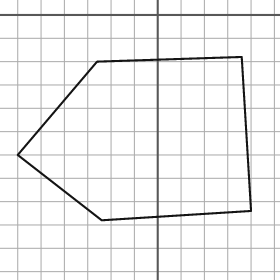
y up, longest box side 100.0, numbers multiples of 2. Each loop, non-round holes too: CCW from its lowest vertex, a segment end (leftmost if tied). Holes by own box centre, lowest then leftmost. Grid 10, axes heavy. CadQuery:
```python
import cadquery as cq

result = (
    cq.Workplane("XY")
    .moveTo(-24.0, -88.0)
    .lineTo(40.0, -84.0)
    .lineTo(36.0, -18.0)
    .lineTo(-26.0, -20.0)
    .lineTo(-60.0, -60.0)
    .close()
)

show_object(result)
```